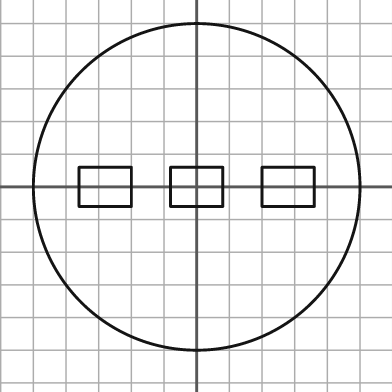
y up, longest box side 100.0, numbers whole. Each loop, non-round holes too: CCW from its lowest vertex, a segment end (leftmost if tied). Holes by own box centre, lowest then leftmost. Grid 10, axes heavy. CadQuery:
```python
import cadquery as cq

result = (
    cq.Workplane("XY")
    .moveTo(0.0, 0.0)
    .circle(50.0)
    .moveTo(-36.0, -6.0)
    .lineTo(-20.0, -6.0)
    .lineTo(-20.0, 6.0)
    .lineTo(-36.0, 6.0)
    .close()
    .moveTo(-8.0, -6.0)
    .lineTo(8.0, -6.0)
    .lineTo(8.0, 6.0)
    .lineTo(-8.0, 6.0)
    .close()
    .moveTo(20.0, -6.0)
    .lineTo(36.0, -6.0)
    .lineTo(36.0, 6.0)
    .lineTo(20.0, 6.0)
    .close()
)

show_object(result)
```